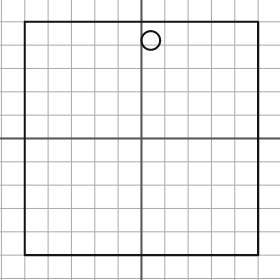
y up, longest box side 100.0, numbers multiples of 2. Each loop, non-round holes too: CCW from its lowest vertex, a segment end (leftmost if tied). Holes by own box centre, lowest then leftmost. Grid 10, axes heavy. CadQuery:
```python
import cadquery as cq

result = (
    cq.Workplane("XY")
    .moveTo(-50.0, -50.0)
    .lineTo(50.0, -50.0)
    .lineTo(50.0, 50.0)
    .lineTo(-50.0, 50.0)
    .close()
    .moveTo(4.0, 42.0)
    .circle(4.0)
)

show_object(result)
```